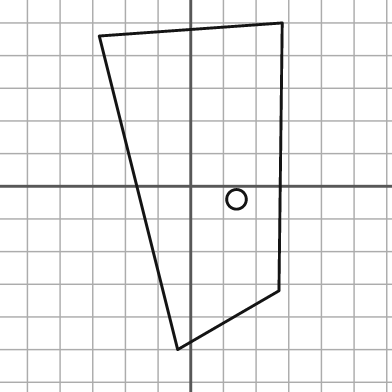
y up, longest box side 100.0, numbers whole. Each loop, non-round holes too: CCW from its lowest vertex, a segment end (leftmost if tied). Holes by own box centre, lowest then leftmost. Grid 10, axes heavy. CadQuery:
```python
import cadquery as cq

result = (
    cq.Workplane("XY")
    .moveTo(-4.0, -50.0)
    .lineTo(27.0, -32.0)
    .lineTo(28.0, 50.0)
    .lineTo(-28.0, 46.0)
    .close()
    .moveTo(14.0, -4.0)
    .circle(3.0)
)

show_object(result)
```